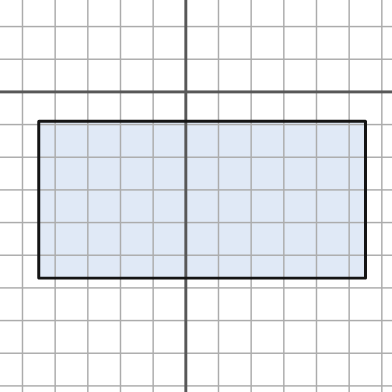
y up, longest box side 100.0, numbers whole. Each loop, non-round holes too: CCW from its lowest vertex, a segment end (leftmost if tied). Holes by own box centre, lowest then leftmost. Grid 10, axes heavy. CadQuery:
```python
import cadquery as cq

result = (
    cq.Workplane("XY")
    .moveTo(-45.0, -57.0)
    .lineTo(55.0, -57.0)
    .lineTo(55.0, -9.0)
    .lineTo(-45.0, -9.0)
    .close()
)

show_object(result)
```